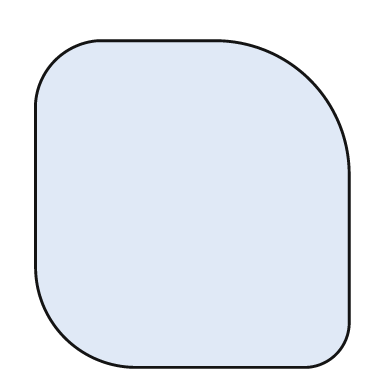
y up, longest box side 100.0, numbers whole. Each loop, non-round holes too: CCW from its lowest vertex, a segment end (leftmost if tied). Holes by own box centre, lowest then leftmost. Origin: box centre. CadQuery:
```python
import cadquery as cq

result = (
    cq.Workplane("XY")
    .moveTo(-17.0, -50.0)
    .lineTo(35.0, -50.0)
    .threePointArc((44.0, -46.0), (48.0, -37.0))
    .lineTo(48.0, 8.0)
    .threePointArc((36.0, 38.0), (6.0, 50.0))
    .lineTo(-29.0, 50.0)
    .threePointArc((-42.0, 44.0), (-48.0, 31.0))
    .lineTo(-48.0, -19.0)
    .threePointArc((-39.0, -41.0), (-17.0, -50.0))
    .close()
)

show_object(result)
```